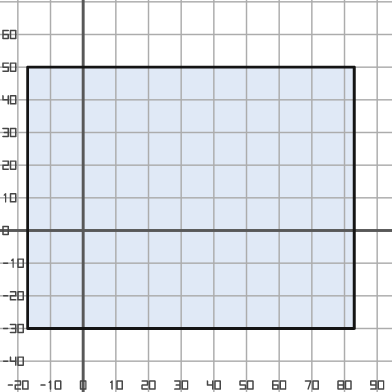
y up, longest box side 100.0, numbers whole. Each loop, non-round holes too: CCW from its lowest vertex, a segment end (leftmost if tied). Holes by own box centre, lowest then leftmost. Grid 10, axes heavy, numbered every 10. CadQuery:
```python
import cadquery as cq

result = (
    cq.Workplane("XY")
    .moveTo(-17.0, -30.0)
    .lineTo(83.0, -30.0)
    .lineTo(83.0, 50.0)
    .lineTo(-17.0, 50.0)
    .close()
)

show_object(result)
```